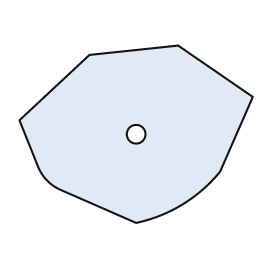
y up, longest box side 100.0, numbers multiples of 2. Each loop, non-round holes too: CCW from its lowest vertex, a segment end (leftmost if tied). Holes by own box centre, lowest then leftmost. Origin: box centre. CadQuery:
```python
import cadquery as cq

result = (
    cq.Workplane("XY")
    .moveTo(0.0, -38.0)
    .threePointArc((20.0, -30.0), (36.0, -16.0))
    .lineTo(50.0, 16.0)
    .lineTo(18.0, 38.0)
    .lineTo(-20.0, 34.0)
    .lineTo(-50.0, 6.0)
    .lineTo(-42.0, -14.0)
    .threePointArc((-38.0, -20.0), (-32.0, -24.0))
    .close()
    .moveTo(0.0, 0.0)
    .circle(4.0)
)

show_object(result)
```